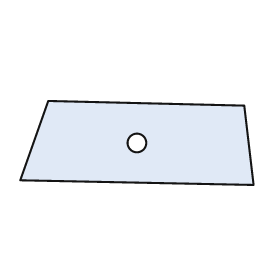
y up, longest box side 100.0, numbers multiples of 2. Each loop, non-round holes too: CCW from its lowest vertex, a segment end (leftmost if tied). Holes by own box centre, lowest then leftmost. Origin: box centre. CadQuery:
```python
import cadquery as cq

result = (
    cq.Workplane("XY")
    .moveTo(50.0, -18.0)
    .lineTo(46.0, 16.0)
    .lineTo(-38.0, 18.0)
    .lineTo(-50.0, -16.0)
    .close()
    .moveTo(0.0, 0.0)
    .circle(4.0)
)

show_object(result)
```